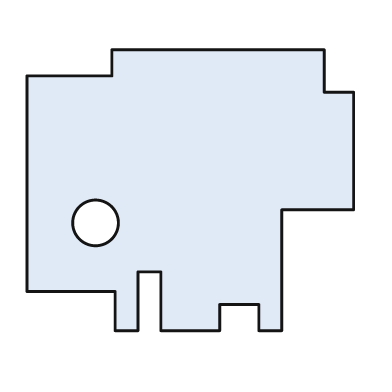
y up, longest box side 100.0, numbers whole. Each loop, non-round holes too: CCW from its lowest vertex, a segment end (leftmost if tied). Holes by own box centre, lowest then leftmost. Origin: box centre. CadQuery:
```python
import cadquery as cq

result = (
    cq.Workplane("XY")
    .moveTo(-23.0, -43.0)
    .lineTo(-16.0, -43.0)
    .lineTo(-16.0, -25.0)
    .lineTo(-9.0, -25.0)
    .lineTo(-9.0, -43.0)
    .lineTo(9.0, -43.0)
    .lineTo(9.0, -35.0)
    .lineTo(21.0, -35.0)
    .lineTo(21.0, -43.0)
    .lineTo(28.0, -43.0)
    .lineTo(28.0, -6.0)
    .lineTo(50.0, -6.0)
    .lineTo(50.0, 30.0)
    .lineTo(41.0, 30.0)
    .lineTo(41.0, 43.0)
    .lineTo(-24.0, 43.0)
    .lineTo(-24.0, 35.0)
    .lineTo(-50.0, 35.0)
    .lineTo(-50.0, -31.0)
    .lineTo(-23.0, -31.0)
    .close()
    .moveTo(-29.0, -10.0)
    .circle(7.0)
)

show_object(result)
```